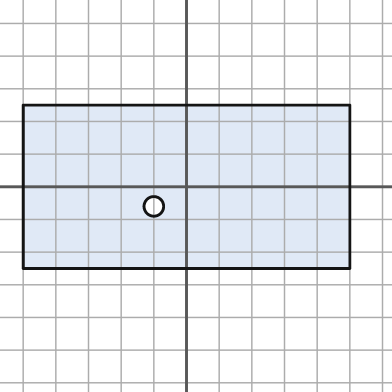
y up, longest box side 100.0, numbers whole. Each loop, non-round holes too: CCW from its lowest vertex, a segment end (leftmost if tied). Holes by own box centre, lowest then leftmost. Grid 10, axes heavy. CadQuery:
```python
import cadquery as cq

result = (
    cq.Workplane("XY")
    .moveTo(-50.0, -25.0)
    .lineTo(50.0, -25.0)
    .lineTo(50.0, 25.0)
    .lineTo(-50.0, 25.0)
    .close()
    .moveTo(-10.0, -6.0)
    .circle(3.0)
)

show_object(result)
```